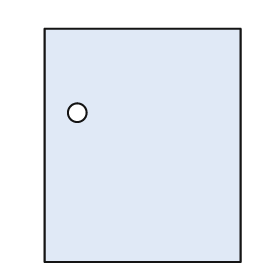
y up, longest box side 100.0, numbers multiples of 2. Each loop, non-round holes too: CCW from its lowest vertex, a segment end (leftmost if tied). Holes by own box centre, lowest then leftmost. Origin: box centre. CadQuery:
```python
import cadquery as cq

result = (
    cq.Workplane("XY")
    .moveTo(-42.0, -50.0)
    .lineTo(42.0, -50.0)
    .lineTo(42.0, 50.0)
    .lineTo(-42.0, 50.0)
    .close()
    .moveTo(-28.0, 14.0)
    .circle(4.0)
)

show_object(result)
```